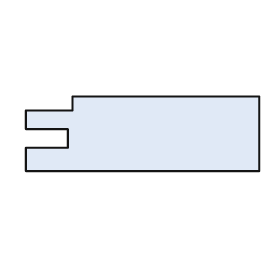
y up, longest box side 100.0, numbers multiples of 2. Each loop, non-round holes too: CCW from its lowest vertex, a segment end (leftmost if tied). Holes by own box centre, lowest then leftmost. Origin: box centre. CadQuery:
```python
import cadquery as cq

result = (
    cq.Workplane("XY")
    .moveTo(-50.0, -16.0)
    .lineTo(50.0, -16.0)
    .lineTo(50.0, 16.0)
    .lineTo(-30.0, 16.0)
    .lineTo(-30.0, 10.0)
    .lineTo(-50.0, 10.0)
    .lineTo(-50.0, 2.0)
    .lineTo(-32.0, 2.0)
    .lineTo(-32.0, -6.0)
    .lineTo(-50.0, -6.0)
    .close()
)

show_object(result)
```